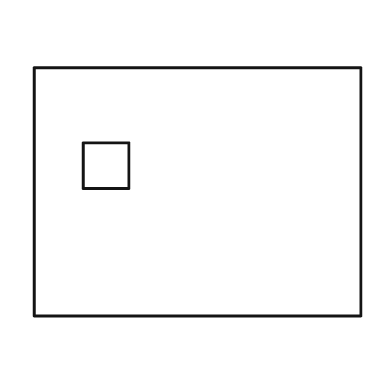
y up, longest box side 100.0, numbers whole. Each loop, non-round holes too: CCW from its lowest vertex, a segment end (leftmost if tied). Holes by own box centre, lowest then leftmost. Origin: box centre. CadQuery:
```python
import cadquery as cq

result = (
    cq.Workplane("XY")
    .moveTo(-50.0, -38.0)
    .lineTo(50.0, -38.0)
    .lineTo(50.0, 38.0)
    .lineTo(-50.0, 38.0)
    .close()
    .moveTo(-35.0, 1.0)
    .lineTo(-21.0, 1.0)
    .lineTo(-21.0, 15.0)
    .lineTo(-35.0, 15.0)
    .close()
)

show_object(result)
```